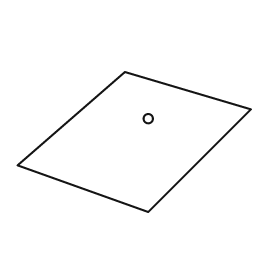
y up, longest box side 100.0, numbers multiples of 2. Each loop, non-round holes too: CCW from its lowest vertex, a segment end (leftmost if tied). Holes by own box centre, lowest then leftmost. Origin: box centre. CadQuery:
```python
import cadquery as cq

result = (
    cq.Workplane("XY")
    .moveTo(6.0, -30.0)
    .lineTo(50.0, 14.0)
    .lineTo(-4.0, 30.0)
    .lineTo(-50.0, -10.0)
    .close()
    .moveTo(6.0, 10.0)
    .circle(2.0)
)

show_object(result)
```